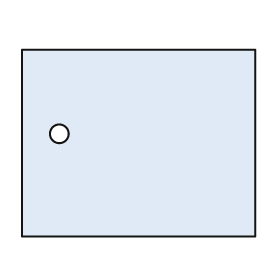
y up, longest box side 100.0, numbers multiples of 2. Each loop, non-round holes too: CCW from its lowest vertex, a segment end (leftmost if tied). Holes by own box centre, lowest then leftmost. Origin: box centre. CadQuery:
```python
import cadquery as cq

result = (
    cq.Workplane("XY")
    .moveTo(-50.0, -40.0)
    .lineTo(50.0, -40.0)
    .lineTo(50.0, 40.0)
    .lineTo(-50.0, 40.0)
    .close()
    .moveTo(-34.0, 4.0)
    .circle(4.0)
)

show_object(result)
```